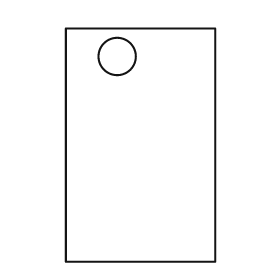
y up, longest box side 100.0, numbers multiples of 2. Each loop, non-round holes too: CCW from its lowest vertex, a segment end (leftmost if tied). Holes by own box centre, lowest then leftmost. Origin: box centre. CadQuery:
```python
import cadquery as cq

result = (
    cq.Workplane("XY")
    .moveTo(-32.0, -50.0)
    .lineTo(32.0, -50.0)
    .lineTo(32.0, 50.0)
    .lineTo(-32.0, 50.0)
    .close()
    .moveTo(-10.0, 38.0)
    .circle(8.0)
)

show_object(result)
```